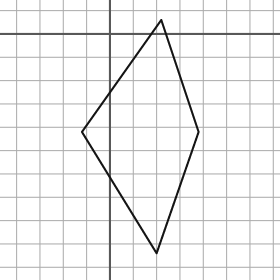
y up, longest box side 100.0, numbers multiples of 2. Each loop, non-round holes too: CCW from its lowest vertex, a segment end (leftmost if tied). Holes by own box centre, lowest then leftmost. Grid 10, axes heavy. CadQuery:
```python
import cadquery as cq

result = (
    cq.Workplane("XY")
    .moveTo(20.0, -94.0)
    .lineTo(38.0, -42.0)
    .lineTo(22.0, 6.0)
    .lineTo(-12.0, -42.0)
    .close()
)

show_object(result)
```